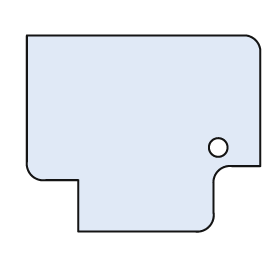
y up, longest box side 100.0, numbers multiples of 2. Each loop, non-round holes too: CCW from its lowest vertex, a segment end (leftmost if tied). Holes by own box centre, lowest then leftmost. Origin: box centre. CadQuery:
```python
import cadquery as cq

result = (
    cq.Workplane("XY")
    .moveTo(-28.0, -42.0)
    .lineTo(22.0, -42.0)
    .threePointArc((28.0, -40.0), (30.0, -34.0))
    .lineTo(30.0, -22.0)
    .threePointArc((32.0, -16.0), (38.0, -14.0))
    .lineTo(50.0, -14.0)
    .lineTo(50.0, 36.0)
    .threePointArc((48.0, 40.0), (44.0, 42.0))
    .lineTo(-50.0, 42.0)
    .lineTo(-50.0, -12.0)
    .threePointArc((-48.0, -18.0), (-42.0, -20.0))
    .lineTo(-28.0, -20.0)
    .close()
    .moveTo(32.0, -6.0)
    .circle(4.0)
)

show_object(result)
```